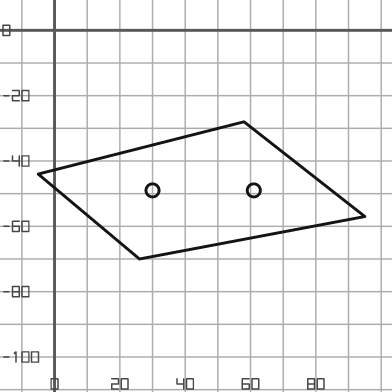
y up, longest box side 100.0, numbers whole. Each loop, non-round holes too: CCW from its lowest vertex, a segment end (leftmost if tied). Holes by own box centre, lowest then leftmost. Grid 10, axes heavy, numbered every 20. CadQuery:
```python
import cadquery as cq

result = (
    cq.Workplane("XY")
    .moveTo(26.0, -70.0)
    .lineTo(95.0, -57.0)
    .lineTo(58.0, -28.0)
    .lineTo(-5.0, -44.0)
    .close()
    .moveTo(30.0, -49.0)
    .circle(2.0)
    .moveTo(61.0, -49.0)
    .circle(2.0)
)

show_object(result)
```